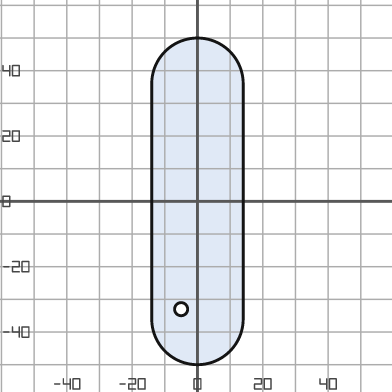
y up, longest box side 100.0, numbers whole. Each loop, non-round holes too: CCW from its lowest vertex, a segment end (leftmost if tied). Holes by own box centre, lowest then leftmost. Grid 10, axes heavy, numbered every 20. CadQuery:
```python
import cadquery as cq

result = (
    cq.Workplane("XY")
    .moveTo(-14.0, -36.0)
    .threePointArc((0.0, -50.0), (14.0, -36.0))
    .lineTo(14.0, 36.0)
    .threePointArc((0.0, 50.0), (-14.0, 36.0))
    .close()
    .moveTo(-5.0, -33.0)
    .circle(2.0)
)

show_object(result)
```